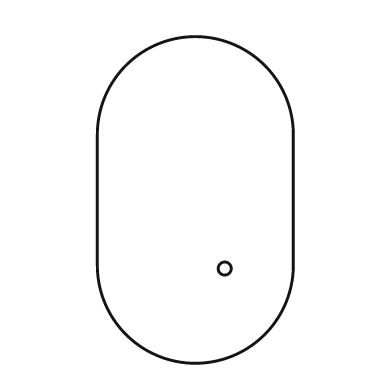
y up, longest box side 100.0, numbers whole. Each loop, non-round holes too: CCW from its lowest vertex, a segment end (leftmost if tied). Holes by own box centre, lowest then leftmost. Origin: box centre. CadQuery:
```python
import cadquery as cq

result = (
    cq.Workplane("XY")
    .moveTo(-30.0, -20.0)
    .threePointArc((0.0, -50.0), (30.0, -20.0))
    .lineTo(30.0, 20.0)
    .threePointArc((0.0, 50.0), (-30.0, 20.0))
    .close()
    .moveTo(9.0, -21.0)
    .circle(2.0)
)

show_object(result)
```